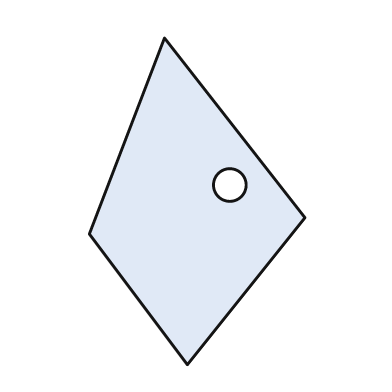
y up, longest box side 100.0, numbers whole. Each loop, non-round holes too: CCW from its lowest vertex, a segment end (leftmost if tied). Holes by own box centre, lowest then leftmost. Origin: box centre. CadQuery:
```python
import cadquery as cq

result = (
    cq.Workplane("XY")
    .moveTo(-3.0, -50.0)
    .lineTo(33.0, -5.0)
    .lineTo(-10.0, 50.0)
    .lineTo(-33.0, -10.0)
    .close()
    .moveTo(10.0, 5.0)
    .circle(5.0)
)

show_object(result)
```